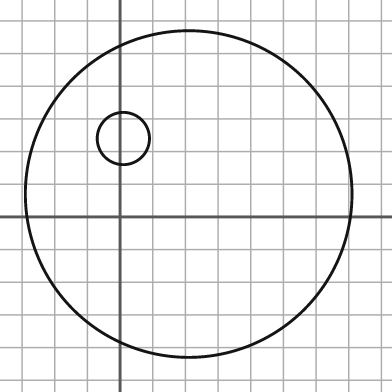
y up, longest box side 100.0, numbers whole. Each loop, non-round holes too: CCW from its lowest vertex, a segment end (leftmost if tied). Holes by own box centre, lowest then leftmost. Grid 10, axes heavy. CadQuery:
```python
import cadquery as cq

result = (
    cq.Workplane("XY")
    .moveTo(21.0, 7.0)
    .circle(50.0)
    .moveTo(1.0, 24.0)
    .circle(8.0)
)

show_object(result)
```